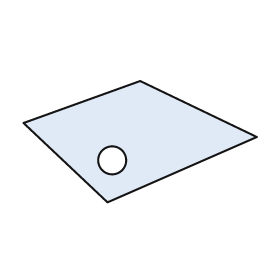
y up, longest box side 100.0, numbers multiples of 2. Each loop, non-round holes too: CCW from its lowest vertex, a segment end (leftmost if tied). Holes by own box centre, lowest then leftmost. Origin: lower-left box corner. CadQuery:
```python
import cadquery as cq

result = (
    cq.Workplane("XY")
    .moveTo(36.0, 0.0)
    .lineTo(100.0, 28.0)
    .lineTo(50.0, 52.0)
    .lineTo(0.0, 34.0)
    .close()
    .moveTo(38.0, 18.0)
    .circle(6.0)
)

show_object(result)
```